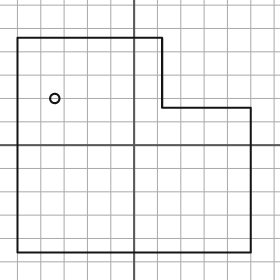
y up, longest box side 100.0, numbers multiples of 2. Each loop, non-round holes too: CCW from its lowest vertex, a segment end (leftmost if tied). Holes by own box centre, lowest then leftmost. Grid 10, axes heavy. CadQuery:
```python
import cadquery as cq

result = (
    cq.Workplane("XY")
    .moveTo(-50.0, -46.0)
    .lineTo(50.0, -46.0)
    .lineTo(50.0, 16.0)
    .lineTo(12.0, 16.0)
    .lineTo(12.0, 46.0)
    .lineTo(-50.0, 46.0)
    .close()
    .moveTo(-34.0, 20.0)
    .circle(2.0)
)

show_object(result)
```